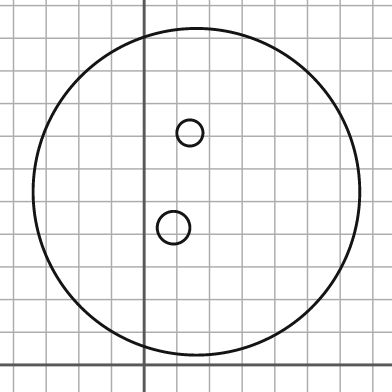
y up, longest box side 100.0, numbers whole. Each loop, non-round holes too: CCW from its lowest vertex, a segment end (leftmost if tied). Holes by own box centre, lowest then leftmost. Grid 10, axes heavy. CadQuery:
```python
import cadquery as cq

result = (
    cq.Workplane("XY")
    .moveTo(16.0, 53.0)
    .circle(50.0)
    .moveTo(9.0, 42.0)
    .circle(5.0)
    .moveTo(14.0, 71.0)
    .circle(4.0)
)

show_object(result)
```